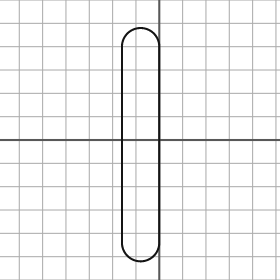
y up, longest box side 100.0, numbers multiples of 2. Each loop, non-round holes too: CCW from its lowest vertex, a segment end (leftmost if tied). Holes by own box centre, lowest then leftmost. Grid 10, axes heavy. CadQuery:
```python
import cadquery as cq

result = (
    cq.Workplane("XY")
    .moveTo(-16.0, -44.0)
    .threePointArc((-8.0, -52.0), (0.0, -44.0))
    .lineTo(0.0, 40.0)
    .threePointArc((-8.0, 48.0), (-16.0, 40.0))
    .close()
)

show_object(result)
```